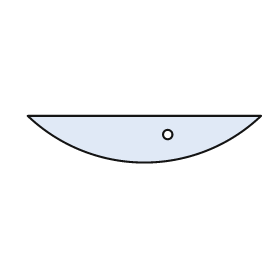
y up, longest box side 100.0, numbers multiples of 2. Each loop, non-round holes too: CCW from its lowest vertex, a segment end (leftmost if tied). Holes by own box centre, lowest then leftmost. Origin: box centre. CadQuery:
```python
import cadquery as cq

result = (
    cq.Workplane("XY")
    .moveTo(-50.0, 10.0)
    .threePointArc((0.0, -10.0), (50.0, 10.0))
    .close()
    .moveTo(10.0, 2.0)
    .circle(2.0)
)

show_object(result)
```